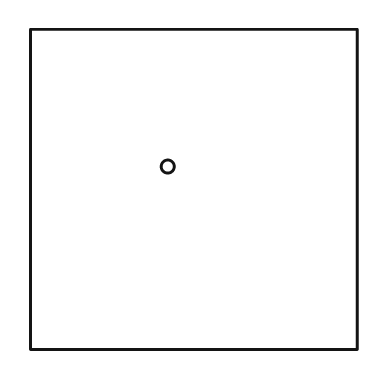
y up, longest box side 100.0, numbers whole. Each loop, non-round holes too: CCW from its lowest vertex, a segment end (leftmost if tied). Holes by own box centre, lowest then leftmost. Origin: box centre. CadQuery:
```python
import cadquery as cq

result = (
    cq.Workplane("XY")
    .moveTo(-50.0, -49.0)
    .lineTo(50.0, -49.0)
    .lineTo(50.0, 49.0)
    .lineTo(-50.0, 49.0)
    .close()
    .moveTo(-8.0, 7.0)
    .circle(2.0)
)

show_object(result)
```